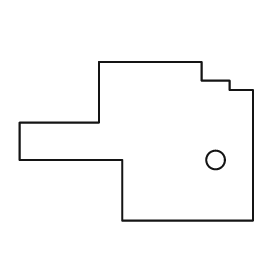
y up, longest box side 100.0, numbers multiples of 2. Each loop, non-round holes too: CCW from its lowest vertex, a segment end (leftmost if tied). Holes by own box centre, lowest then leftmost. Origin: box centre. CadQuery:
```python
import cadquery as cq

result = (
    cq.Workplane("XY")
    .moveTo(-6.0, -34.0)
    .lineTo(50.0, -34.0)
    .lineTo(50.0, 22.0)
    .lineTo(40.0, 22.0)
    .lineTo(40.0, 26.0)
    .lineTo(28.0, 26.0)
    .lineTo(28.0, 34.0)
    .lineTo(-16.0, 34.0)
    .lineTo(-16.0, 8.0)
    .lineTo(-50.0, 8.0)
    .lineTo(-50.0, -8.0)
    .lineTo(-6.0, -8.0)
    .close()
    .moveTo(34.0, -8.0)
    .circle(4.0)
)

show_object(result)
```